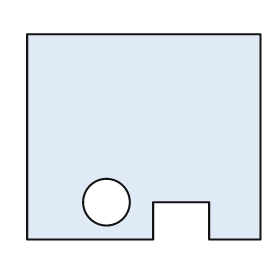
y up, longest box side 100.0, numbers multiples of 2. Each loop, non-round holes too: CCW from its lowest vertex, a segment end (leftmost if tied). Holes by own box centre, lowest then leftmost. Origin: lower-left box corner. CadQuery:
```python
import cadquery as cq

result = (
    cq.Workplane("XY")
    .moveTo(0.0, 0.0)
    .lineTo(54.0, 0.0)
    .lineTo(54.0, 16.0)
    .lineTo(78.0, 16.0)
    .lineTo(78.0, 0.0)
    .lineTo(100.0, 0.0)
    .lineTo(100.0, 88.0)
    .lineTo(0.0, 88.0)
    .close()
    .moveTo(34.0, 16.0)
    .circle(10.0)
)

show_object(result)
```